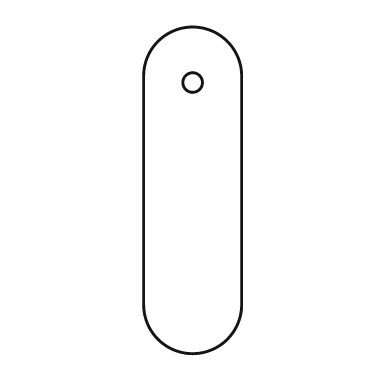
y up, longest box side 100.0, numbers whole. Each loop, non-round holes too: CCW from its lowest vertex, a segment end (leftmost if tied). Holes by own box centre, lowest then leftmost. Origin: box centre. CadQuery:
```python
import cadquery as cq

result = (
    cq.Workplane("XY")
    .moveTo(-15.0, -35.0)
    .threePointArc((0.0, -50.0), (15.0, -35.0))
    .lineTo(15.0, 35.0)
    .threePointArc((0.0, 50.0), (-15.0, 35.0))
    .close()
    .moveTo(0.0, 33.0)
    .circle(3.0)
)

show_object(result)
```